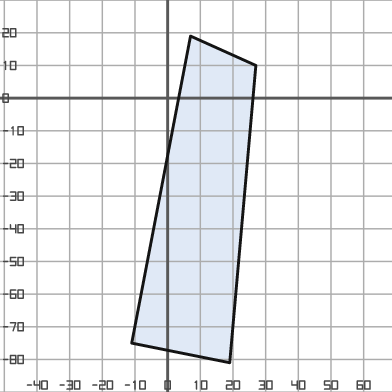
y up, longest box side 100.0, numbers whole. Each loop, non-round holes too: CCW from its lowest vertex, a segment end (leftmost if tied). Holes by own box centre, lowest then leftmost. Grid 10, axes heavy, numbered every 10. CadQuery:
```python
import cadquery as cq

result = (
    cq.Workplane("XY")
    .moveTo(19.0, -81.0)
    .lineTo(27.0, 10.0)
    .lineTo(7.0, 19.0)
    .lineTo(-11.0, -75.0)
    .close()
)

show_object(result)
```